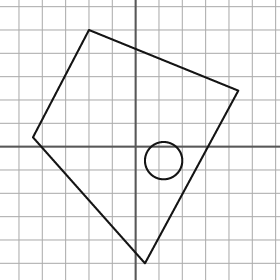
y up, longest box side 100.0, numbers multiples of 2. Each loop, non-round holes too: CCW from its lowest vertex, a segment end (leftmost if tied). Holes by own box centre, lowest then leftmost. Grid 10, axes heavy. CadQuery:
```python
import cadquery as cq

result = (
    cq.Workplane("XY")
    .moveTo(4.0, -50.0)
    .lineTo(44.0, 24.0)
    .lineTo(-20.0, 50.0)
    .lineTo(-44.0, 4.0)
    .close()
    .moveTo(12.0, -6.0)
    .circle(8.0)
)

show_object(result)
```